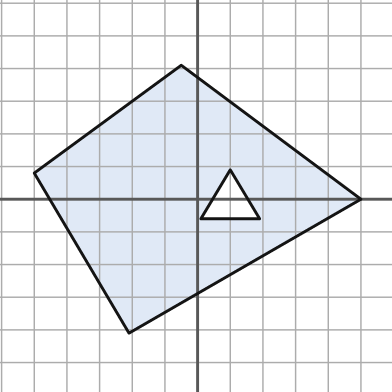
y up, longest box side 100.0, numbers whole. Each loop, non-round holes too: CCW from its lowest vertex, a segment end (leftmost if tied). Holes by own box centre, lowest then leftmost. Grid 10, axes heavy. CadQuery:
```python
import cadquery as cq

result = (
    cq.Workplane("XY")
    .moveTo(-21.0, -41.0)
    .lineTo(50.0, 0.0)
    .lineTo(-5.0, 41.0)
    .lineTo(-50.0, 8.0)
    .close()
    .moveTo(1.0, -6.0)
    .lineTo(19.0, -6.0)
    .lineTo(10.0, 9.0)
    .close()
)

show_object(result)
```